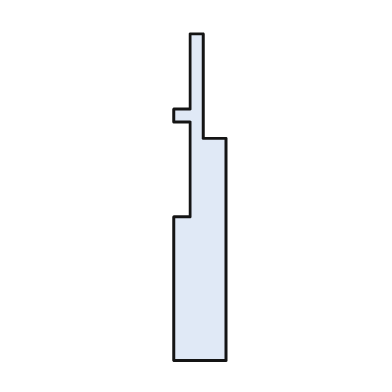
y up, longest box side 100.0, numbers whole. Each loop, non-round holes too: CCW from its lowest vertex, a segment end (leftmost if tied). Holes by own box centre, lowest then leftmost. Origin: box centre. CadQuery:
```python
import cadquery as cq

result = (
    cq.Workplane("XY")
    .moveTo(-8.0, -50.0)
    .lineTo(8.0, -50.0)
    .lineTo(8.0, 18.0)
    .lineTo(1.0, 18.0)
    .lineTo(1.0, 50.0)
    .lineTo(-3.0, 50.0)
    .lineTo(-3.0, 27.0)
    .lineTo(-8.0, 27.0)
    .lineTo(-8.0, 23.0)
    .lineTo(-3.0, 23.0)
    .lineTo(-3.0, -6.0)
    .lineTo(-8.0, -6.0)
    .close()
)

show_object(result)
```